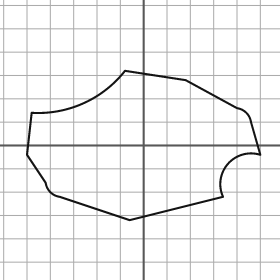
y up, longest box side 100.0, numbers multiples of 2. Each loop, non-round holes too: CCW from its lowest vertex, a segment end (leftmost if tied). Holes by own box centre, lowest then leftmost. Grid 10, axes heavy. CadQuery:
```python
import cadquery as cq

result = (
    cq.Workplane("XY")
    .moveTo(-6.0, -32.0)
    .lineTo(34.0, -22.0)
    .threePointArc((36.0, -8.0), (50.0, -4.0))
    .lineTo(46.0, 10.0)
    .threePointArc((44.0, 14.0), (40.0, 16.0))
    .lineTo(18.0, 28.0)
    .lineTo(-8.0, 32.0)
    .threePointArc((-26.0, 18.0), (-48.0, 14.0))
    .lineTo(-50.0, -4.0)
    .lineTo(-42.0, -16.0)
    .threePointArc((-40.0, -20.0), (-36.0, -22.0))
    .close()
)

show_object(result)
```